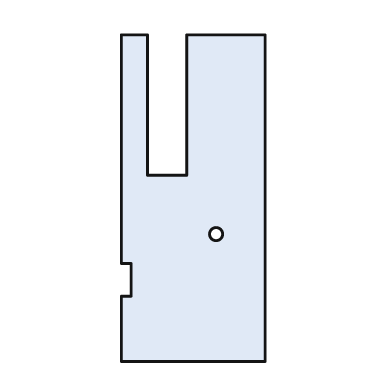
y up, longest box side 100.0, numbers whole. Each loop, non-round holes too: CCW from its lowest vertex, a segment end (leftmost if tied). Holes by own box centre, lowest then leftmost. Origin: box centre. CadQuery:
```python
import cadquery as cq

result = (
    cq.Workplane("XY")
    .moveTo(-22.0, -50.0)
    .lineTo(22.0, -50.0)
    .lineTo(22.0, 50.0)
    .lineTo(-2.0, 50.0)
    .lineTo(-2.0, 7.0)
    .lineTo(-14.0, 7.0)
    .lineTo(-14.0, 50.0)
    .lineTo(-22.0, 50.0)
    .lineTo(-22.0, -20.0)
    .lineTo(-19.0, -20.0)
    .lineTo(-19.0, -30.0)
    .lineTo(-22.0, -30.0)
    .close()
    .moveTo(7.0, -11.0)
    .circle(2.0)
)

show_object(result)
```